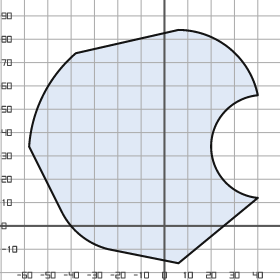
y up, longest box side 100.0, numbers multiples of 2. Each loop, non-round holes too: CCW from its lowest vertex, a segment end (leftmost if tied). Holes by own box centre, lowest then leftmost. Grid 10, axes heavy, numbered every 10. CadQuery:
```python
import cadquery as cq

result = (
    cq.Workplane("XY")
    .moveTo(6.0, -16.0)
    .lineTo(40.0, 12.0)
    .threePointArc((20.0, 34.0), (40.0, 56.0))
    .threePointArc((28.0, 76.0), (6.0, 84.0))
    .lineTo(-38.0, 74.0)
    .threePointArc((-52.0, 56.0), (-58.0, 34.0))
    .lineTo(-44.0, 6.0)
    .threePointArc((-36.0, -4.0), (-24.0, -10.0))
    .close()
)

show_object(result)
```